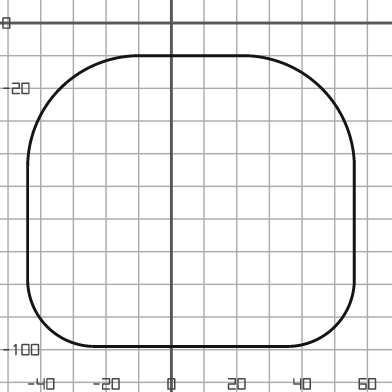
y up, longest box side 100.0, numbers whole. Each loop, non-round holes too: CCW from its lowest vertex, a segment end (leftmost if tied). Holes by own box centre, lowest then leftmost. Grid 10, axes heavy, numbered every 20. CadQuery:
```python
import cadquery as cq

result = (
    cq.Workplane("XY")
    .moveTo(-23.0, -99.0)
    .lineTo(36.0, -99.0)
    .threePointArc((50.0, -93.0), (56.0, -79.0))
    .lineTo(56.0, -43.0)
    .threePointArc((46.0, -20.0), (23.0, -10.0))
    .lineTo(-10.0, -10.0)
    .threePointArc((-34.0, -20.0), (-44.0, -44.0))
    .lineTo(-44.0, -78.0)
    .threePointArc((-38.0, -93.0), (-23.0, -99.0))
    .close()
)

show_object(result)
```